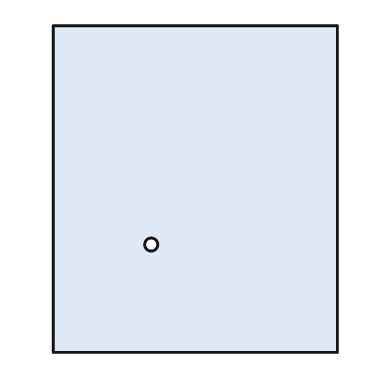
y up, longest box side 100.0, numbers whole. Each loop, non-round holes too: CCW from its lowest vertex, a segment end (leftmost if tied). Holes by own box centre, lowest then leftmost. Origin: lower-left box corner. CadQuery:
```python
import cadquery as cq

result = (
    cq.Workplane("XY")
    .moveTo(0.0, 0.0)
    .lineTo(87.0, 0.0)
    .lineTo(87.0, 100.0)
    .lineTo(0.0, 100.0)
    .close()
    .moveTo(30.0, 33.0)
    .circle(2.0)
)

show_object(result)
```